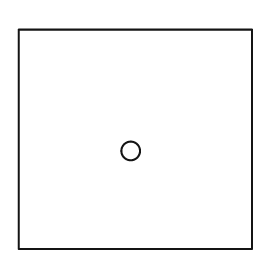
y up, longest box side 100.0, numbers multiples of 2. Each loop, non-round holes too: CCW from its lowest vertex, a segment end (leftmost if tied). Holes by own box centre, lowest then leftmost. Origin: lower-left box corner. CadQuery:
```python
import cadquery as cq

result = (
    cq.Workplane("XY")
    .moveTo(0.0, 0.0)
    .lineTo(100.0, 0.0)
    .lineTo(100.0, 94.0)
    .lineTo(0.0, 94.0)
    .close()
    .moveTo(48.0, 42.0)
    .circle(4.0)
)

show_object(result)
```